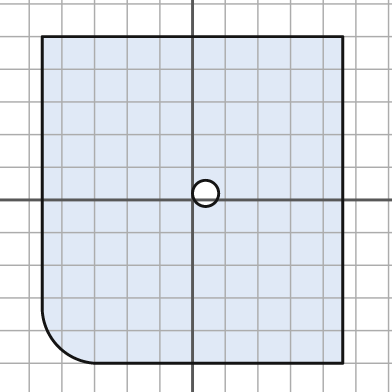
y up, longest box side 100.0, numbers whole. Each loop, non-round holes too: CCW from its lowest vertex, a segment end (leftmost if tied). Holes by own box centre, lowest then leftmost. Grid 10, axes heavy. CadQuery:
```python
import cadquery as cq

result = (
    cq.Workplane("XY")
    .moveTo(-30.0, -50.0)
    .lineTo(46.0, -50.0)
    .lineTo(46.0, 50.0)
    .lineTo(-46.0, 50.0)
    .lineTo(-46.0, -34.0)
    .threePointArc((-41.0, -45.0), (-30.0, -50.0))
    .close()
    .moveTo(4.0, 2.0)
    .circle(4.0)
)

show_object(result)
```